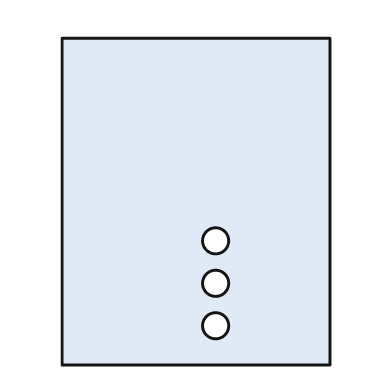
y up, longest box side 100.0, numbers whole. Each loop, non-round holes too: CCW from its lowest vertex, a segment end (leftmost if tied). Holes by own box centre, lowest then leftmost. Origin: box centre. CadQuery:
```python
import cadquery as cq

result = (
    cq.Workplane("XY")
    .moveTo(-41.0, -50.0)
    .lineTo(41.0, -50.0)
    .lineTo(41.0, 50.0)
    .lineTo(-41.0, 50.0)
    .close()
    .moveTo(6.0, -38.0)
    .circle(4.0)
    .moveTo(6.0, -25.0)
    .circle(4.0)
    .moveTo(6.0, -12.0)
    .circle(4.0)
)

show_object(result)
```